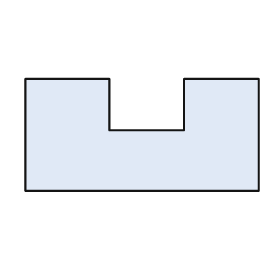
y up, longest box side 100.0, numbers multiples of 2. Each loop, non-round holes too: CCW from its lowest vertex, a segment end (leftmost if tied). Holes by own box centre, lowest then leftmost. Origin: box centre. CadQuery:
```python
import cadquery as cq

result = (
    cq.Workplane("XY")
    .moveTo(-50.0, -24.0)
    .lineTo(50.0, -24.0)
    .lineTo(50.0, 24.0)
    .lineTo(18.0, 24.0)
    .lineTo(18.0, 2.0)
    .lineTo(-14.0, 2.0)
    .lineTo(-14.0, 24.0)
    .lineTo(-50.0, 24.0)
    .close()
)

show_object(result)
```